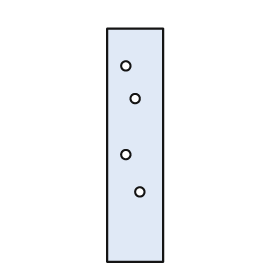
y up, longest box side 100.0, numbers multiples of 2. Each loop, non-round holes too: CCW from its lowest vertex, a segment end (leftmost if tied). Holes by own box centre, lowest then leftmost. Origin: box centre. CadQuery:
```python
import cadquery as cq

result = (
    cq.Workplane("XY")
    .moveTo(-12.0, -50.0)
    .lineTo(12.0, -50.0)
    .lineTo(12.0, 50.0)
    .lineTo(-12.0, 50.0)
    .close()
    .moveTo(2.0, -20.0)
    .circle(2.0)
    .moveTo(-4.0, -4.0)
    .circle(2.0)
    .moveTo(0.0, 20.0)
    .circle(2.0)
    .moveTo(-4.0, 34.0)
    .circle(2.0)
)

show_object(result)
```